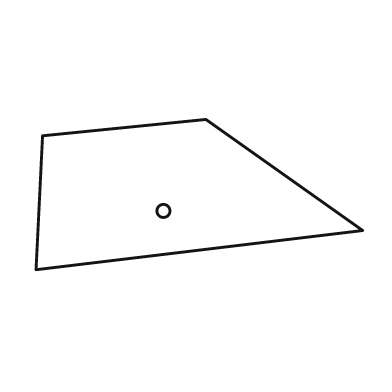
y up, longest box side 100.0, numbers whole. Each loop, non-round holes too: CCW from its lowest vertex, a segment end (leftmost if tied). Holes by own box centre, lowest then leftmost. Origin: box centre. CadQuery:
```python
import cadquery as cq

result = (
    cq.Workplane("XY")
    .moveTo(-50.0, -23.0)
    .lineTo(50.0, -11.0)
    .lineTo(2.0, 23.0)
    .lineTo(-48.0, 18.0)
    .close()
    .moveTo(-11.0, -5.0)
    .circle(2.0)
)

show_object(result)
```